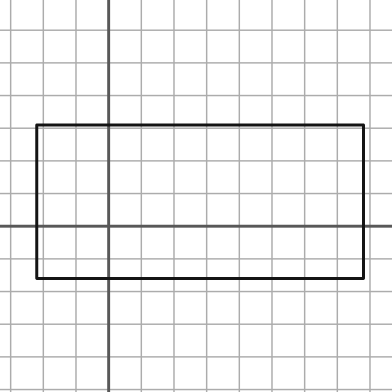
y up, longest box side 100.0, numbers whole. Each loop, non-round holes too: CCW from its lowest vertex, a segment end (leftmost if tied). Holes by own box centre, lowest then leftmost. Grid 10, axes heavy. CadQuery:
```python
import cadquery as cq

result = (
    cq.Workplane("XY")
    .moveTo(-22.0, -16.0)
    .lineTo(78.0, -16.0)
    .lineTo(78.0, 31.0)
    .lineTo(-22.0, 31.0)
    .close()
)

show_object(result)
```